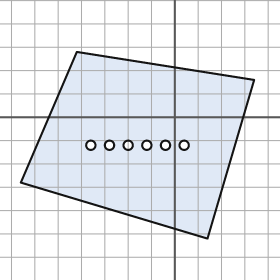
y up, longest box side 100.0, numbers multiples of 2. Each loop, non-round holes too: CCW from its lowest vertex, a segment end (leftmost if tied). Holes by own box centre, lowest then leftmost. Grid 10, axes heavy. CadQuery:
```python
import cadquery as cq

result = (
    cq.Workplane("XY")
    .moveTo(14.0, -52.0)
    .lineTo(34.0, 16.0)
    .lineTo(-42.0, 28.0)
    .lineTo(-66.0, -28.0)
    .close()
    .moveTo(-36.0, -12.0)
    .circle(2.0)
    .moveTo(-28.0, -12.0)
    .circle(2.0)
    .moveTo(-20.0, -12.0)
    .circle(2.0)
    .moveTo(-12.0, -12.0)
    .circle(2.0)
    .moveTo(-4.0, -12.0)
    .circle(2.0)
    .moveTo(4.0, -12.0)
    .circle(2.0)
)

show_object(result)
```